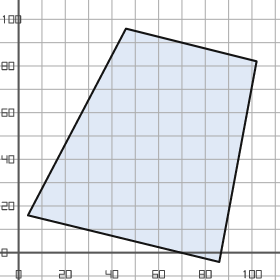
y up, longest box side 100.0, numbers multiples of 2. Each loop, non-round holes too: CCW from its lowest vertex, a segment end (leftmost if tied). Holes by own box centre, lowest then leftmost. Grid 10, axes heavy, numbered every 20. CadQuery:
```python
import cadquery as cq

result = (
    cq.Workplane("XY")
    .moveTo(86.0, -4.0)
    .lineTo(102.0, 82.0)
    .lineTo(46.0, 96.0)
    .lineTo(4.0, 16.0)
    .close()
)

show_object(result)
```